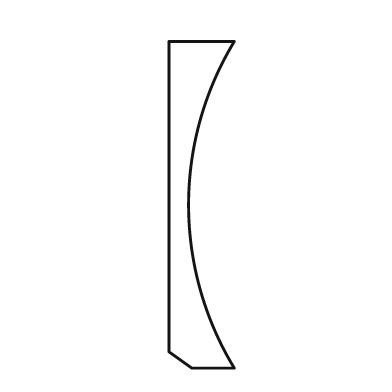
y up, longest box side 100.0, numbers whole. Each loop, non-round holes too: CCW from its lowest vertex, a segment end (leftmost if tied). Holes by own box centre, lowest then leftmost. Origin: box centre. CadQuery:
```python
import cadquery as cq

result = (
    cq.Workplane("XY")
    .moveTo(-3.0, -50.0)
    .lineTo(10.0, -50.0)
    .threePointArc((-4.0, 0.0), (10.0, 50.0))
    .lineTo(-10.0, 50.0)
    .lineTo(-10.0, -45.0)
    .close()
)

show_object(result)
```